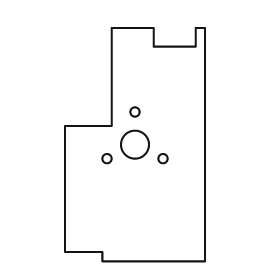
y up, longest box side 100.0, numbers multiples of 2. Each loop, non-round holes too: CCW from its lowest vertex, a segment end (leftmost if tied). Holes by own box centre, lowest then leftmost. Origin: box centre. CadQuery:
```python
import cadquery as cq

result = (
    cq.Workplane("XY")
    .moveTo(-14.0, -50.0)
    .lineTo(30.0, -50.0)
    .lineTo(30.0, 50.0)
    .lineTo(26.0, 50.0)
    .lineTo(26.0, 42.0)
    .lineTo(8.0, 42.0)
    .lineTo(8.0, 50.0)
    .lineTo(-10.0, 50.0)
    .lineTo(-10.0, 8.0)
    .lineTo(-30.0, 8.0)
    .lineTo(-30.0, -46.0)
    .lineTo(-14.0, -46.0)
    .close()
    .moveTo(-12.0, -6.0)
    .circle(2.0)
    .moveTo(12.0, -6.0)
    .circle(2.0)
    .moveTo(0.0, 0.0)
    .circle(6.0)
    .moveTo(0.0, 14.0)
    .circle(2.0)
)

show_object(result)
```